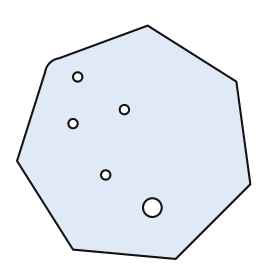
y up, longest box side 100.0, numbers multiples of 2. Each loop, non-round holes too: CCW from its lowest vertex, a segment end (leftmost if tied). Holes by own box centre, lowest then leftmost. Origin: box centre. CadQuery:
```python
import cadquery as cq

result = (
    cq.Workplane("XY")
    .moveTo(18.0, -50.0)
    .lineTo(50.0, -18.0)
    .lineTo(44.0, 26.0)
    .lineTo(6.0, 50.0)
    .lineTo(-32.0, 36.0)
    .threePointArc((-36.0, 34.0), (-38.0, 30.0))
    .lineTo(-50.0, -8.0)
    .lineTo(-26.0, -46.0)
    .close()
    .moveTo(8.0, -28.0)
    .circle(4.0)
    .moveTo(-12.0, -14.0)
    .circle(2.0)
    .moveTo(-26.0, 8.0)
    .circle(2.0)
    .moveTo(-4.0, 14.0)
    .circle(2.0)
    .moveTo(-24.0, 28.0)
    .circle(2.0)
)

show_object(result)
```